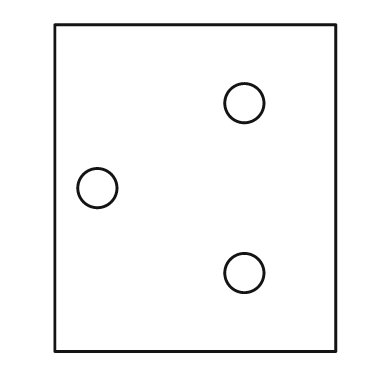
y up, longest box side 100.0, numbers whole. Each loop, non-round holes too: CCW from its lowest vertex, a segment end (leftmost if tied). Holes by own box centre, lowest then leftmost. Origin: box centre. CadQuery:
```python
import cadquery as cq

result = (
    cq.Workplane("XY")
    .moveTo(-43.0, -50.0)
    .lineTo(43.0, -50.0)
    .lineTo(43.0, 50.0)
    .lineTo(-43.0, 50.0)
    .close()
    .moveTo(15.0, -26.0)
    .circle(6.0)
    .moveTo(-30.0, 0.0)
    .circle(6.0)
    .moveTo(15.0, 26.0)
    .circle(6.0)
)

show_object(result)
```